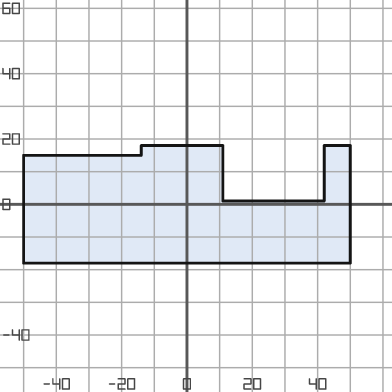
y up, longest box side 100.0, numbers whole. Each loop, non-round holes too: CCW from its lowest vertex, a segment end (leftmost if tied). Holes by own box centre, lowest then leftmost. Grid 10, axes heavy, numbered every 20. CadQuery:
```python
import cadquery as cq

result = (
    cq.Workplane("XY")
    .moveTo(-50.0, -18.0)
    .lineTo(50.0, -18.0)
    .lineTo(50.0, 18.0)
    .lineTo(42.0, 18.0)
    .lineTo(42.0, 1.0)
    .lineTo(11.0, 1.0)
    .lineTo(11.0, 18.0)
    .lineTo(-14.0, 18.0)
    .lineTo(-14.0, 15.0)
    .lineTo(-50.0, 15.0)
    .close()
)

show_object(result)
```